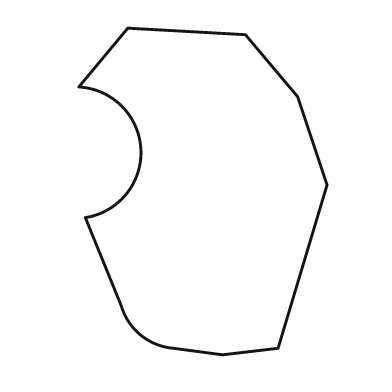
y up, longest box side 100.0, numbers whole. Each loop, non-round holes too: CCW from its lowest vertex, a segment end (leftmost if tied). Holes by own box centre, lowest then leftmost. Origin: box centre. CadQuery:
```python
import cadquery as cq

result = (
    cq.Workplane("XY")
    .moveTo(6.0, -50.0)
    .lineTo(23.0, -48.0)
    .lineTo(38.0, 2.0)
    .lineTo(29.0, 29.0)
    .lineTo(13.0, 48.0)
    .lineTo(-23.0, 50.0)
    .lineTo(-38.0, 32.0)
    .threePointArc((-19.0, 13.0), (-36.0, -8.0))
    .lineTo(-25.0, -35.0)
    .threePointArc((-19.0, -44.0), (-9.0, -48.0))
    .close()
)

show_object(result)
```